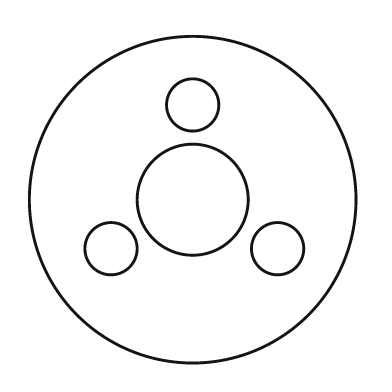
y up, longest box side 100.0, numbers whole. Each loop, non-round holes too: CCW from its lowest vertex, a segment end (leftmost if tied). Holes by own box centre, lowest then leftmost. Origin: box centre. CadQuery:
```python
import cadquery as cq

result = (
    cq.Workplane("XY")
    .moveTo(0.0, 0.0)
    .circle(50.0)
    .moveTo(-25.0, -15.0)
    .circle(8.0)
    .moveTo(26.0, -15.0)
    .circle(8.0)
    .moveTo(0.0, 0.0)
    .circle(17.0)
    .moveTo(0.0, 29.0)
    .circle(8.0)
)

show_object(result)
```